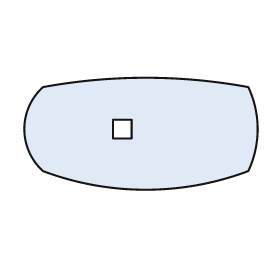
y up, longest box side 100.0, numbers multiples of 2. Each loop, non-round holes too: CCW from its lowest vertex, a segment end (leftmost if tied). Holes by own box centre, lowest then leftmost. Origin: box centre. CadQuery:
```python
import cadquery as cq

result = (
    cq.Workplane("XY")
    .moveTo(-42.0, -16.0)
    .threePointArc((2.0, -24.0), (46.0, -16.0))
    .threePointArc((50.0, 2.0), (46.0, 20.0))
    .threePointArc((2.0, 24.0), (-42.0, 20.0))
    .threePointArc((-50.0, 2.0), (-42.0, -16.0))
    .close()
    .moveTo(-12.0, -2.0)
    .lineTo(-4.0, -2.0)
    .lineTo(-4.0, 6.0)
    .lineTo(-12.0, 6.0)
    .close()
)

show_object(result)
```